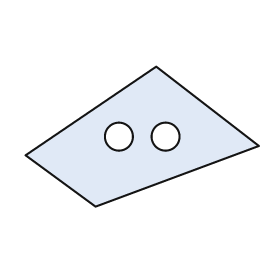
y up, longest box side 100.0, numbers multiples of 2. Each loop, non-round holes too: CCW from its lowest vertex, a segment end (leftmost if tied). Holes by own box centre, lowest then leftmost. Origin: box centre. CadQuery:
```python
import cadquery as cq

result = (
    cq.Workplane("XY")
    .moveTo(-20.0, -30.0)
    .lineTo(50.0, -4.0)
    .lineTo(6.0, 30.0)
    .lineTo(-50.0, -8.0)
    .close()
    .moveTo(-10.0, 0.0)
    .circle(6.0)
    .moveTo(10.0, 0.0)
    .circle(6.0)
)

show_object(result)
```